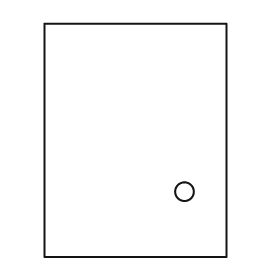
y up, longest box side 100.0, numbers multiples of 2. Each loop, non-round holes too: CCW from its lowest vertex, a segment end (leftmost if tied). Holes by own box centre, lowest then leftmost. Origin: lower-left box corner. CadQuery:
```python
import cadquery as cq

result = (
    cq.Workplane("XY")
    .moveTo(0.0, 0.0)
    .lineTo(78.0, 0.0)
    .lineTo(78.0, 100.0)
    .lineTo(0.0, 100.0)
    .close()
    .moveTo(60.0, 28.0)
    .circle(4.0)
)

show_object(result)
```